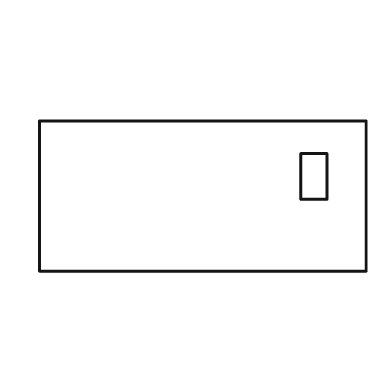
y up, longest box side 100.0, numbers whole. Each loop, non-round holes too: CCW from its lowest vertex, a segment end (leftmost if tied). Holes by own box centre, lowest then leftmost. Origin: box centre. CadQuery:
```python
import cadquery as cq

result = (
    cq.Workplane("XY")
    .moveTo(-50.0, -23.0)
    .lineTo(50.0, -23.0)
    .lineTo(50.0, 23.0)
    .lineTo(-50.0, 23.0)
    .close()
    .moveTo(30.0, -1.0)
    .lineTo(38.0, -1.0)
    .lineTo(38.0, 13.0)
    .lineTo(30.0, 13.0)
    .close()
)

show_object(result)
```